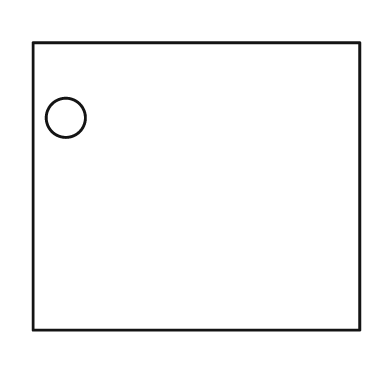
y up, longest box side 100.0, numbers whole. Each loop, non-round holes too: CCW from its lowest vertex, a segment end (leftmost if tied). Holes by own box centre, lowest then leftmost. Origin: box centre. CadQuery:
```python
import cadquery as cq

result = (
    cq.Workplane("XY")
    .moveTo(-50.0, -44.0)
    .lineTo(50.0, -44.0)
    .lineTo(50.0, 44.0)
    .lineTo(-50.0, 44.0)
    .close()
    .moveTo(-40.0, 21.0)
    .circle(6.0)
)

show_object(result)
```